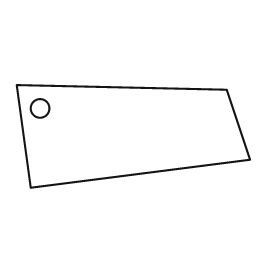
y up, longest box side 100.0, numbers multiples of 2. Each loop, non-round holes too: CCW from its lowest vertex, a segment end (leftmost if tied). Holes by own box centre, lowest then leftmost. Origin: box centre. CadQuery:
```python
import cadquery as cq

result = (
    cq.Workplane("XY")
    .moveTo(-44.0, -22.0)
    .lineTo(50.0, -10.0)
    .lineTo(40.0, 20.0)
    .lineTo(-50.0, 22.0)
    .close()
    .moveTo(-40.0, 12.0)
    .circle(4.0)
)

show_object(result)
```